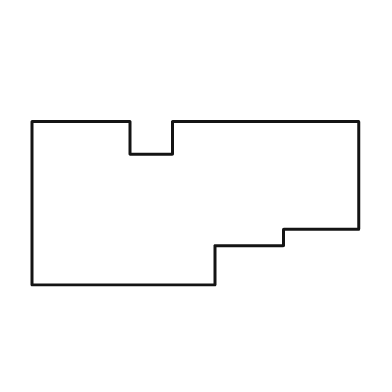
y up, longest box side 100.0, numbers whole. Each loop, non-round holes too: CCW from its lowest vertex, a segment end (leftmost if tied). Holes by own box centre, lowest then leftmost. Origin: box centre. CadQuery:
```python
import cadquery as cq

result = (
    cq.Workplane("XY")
    .moveTo(-50.0, -25.0)
    .lineTo(6.0, -25.0)
    .lineTo(6.0, -13.0)
    .lineTo(27.0, -13.0)
    .lineTo(27.0, -8.0)
    .lineTo(50.0, -8.0)
    .lineTo(50.0, 25.0)
    .lineTo(-7.0, 25.0)
    .lineTo(-7.0, 15.0)
    .lineTo(-20.0, 15.0)
    .lineTo(-20.0, 25.0)
    .lineTo(-50.0, 25.0)
    .close()
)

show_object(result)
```